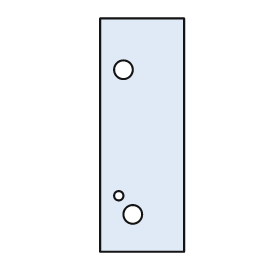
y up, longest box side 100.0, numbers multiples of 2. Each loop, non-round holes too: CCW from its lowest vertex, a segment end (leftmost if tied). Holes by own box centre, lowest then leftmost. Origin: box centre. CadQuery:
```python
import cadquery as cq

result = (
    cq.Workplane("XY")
    .moveTo(-18.0, -50.0)
    .lineTo(18.0, -50.0)
    .lineTo(18.0, 50.0)
    .lineTo(-18.0, 50.0)
    .close()
    .moveTo(-4.0, -34.0)
    .circle(4.0)
    .moveTo(-10.0, -26.0)
    .circle(2.0)
    .moveTo(-8.0, 28.0)
    .circle(4.0)
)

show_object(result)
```